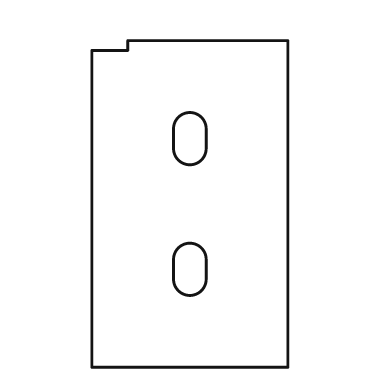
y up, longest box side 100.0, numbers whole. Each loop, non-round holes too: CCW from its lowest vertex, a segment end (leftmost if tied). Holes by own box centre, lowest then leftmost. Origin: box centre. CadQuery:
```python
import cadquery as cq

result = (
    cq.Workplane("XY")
    .moveTo(-30.0, -50.0)
    .lineTo(30.0, -50.0)
    .lineTo(30.0, 50.0)
    .lineTo(-19.0, 50.0)
    .lineTo(-19.0, 47.0)
    .lineTo(-30.0, 47.0)
    .close()
    .moveTo(-5.0, -23.0)
    .threePointArc((0.0, -28.0), (5.0, -23.0))
    .lineTo(5.0, -17.0)
    .threePointArc((0.0, -12.0), (-5.0, -17.0))
    .close()
    .moveTo(-5.0, 17.0)
    .threePointArc((0.0, 12.0), (5.0, 17.0))
    .lineTo(5.0, 23.0)
    .threePointArc((0.0, 28.0), (-5.0, 23.0))
    .close()
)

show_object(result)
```